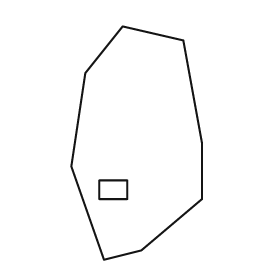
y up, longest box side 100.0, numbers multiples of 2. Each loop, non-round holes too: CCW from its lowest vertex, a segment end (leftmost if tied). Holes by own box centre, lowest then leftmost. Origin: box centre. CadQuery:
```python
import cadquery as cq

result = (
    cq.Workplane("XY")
    .moveTo(-14.0, -50.0)
    .lineTo(2.0, -46.0)
    .lineTo(28.0, -24.0)
    .lineTo(28.0, 0.0)
    .lineTo(20.0, 44.0)
    .lineTo(-6.0, 50.0)
    .lineTo(-22.0, 30.0)
    .lineTo(-28.0, -10.0)
    .close()
    .moveTo(-16.0, -24.0)
    .lineTo(-4.0, -24.0)
    .lineTo(-4.0, -16.0)
    .lineTo(-16.0, -16.0)
    .close()
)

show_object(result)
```